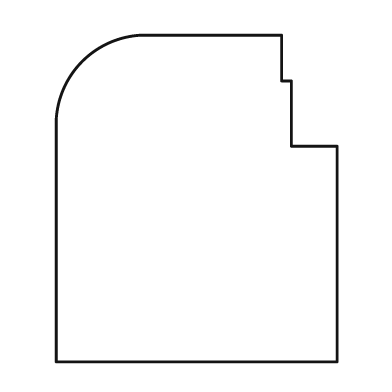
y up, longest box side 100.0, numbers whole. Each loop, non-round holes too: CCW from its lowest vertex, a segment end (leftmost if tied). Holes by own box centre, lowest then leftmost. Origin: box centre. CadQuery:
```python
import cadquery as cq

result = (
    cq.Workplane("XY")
    .moveTo(-43.0, -50.0)
    .lineTo(43.0, -50.0)
    .lineTo(43.0, 16.0)
    .lineTo(29.0, 16.0)
    .lineTo(29.0, 36.0)
    .lineTo(26.0, 36.0)
    .lineTo(26.0, 50.0)
    .lineTo(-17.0, 50.0)
    .threePointArc((-35.0, 42.0), (-43.0, 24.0))
    .close()
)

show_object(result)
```